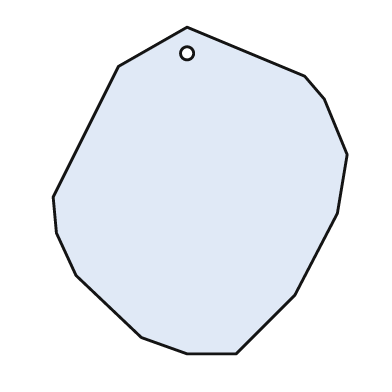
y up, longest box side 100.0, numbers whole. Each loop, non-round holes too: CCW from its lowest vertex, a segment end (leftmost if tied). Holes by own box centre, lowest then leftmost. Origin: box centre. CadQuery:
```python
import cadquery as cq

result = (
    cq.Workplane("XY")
    .moveTo(-4.0, -50.0)
    .lineTo(11.0, -50.0)
    .lineTo(29.0, -32.0)
    .lineTo(42.0, -7.0)
    .lineTo(45.0, 11.0)
    .lineTo(38.0, 28.0)
    .lineTo(32.0, 35.0)
    .lineTo(-4.0, 50.0)
    .lineTo(-25.0, 38.0)
    .lineTo(-45.0, -2.0)
    .lineTo(-44.0, -13.0)
    .lineTo(-38.0, -26.0)
    .lineTo(-18.0, -45.0)
    .close()
    .moveTo(-4.0, 42.0)
    .circle(2.0)
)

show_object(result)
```